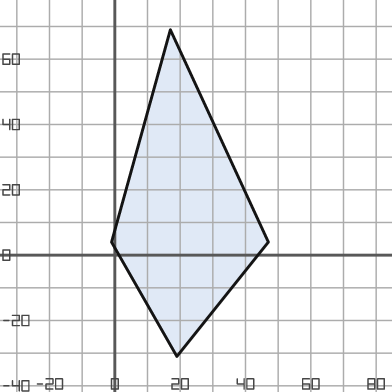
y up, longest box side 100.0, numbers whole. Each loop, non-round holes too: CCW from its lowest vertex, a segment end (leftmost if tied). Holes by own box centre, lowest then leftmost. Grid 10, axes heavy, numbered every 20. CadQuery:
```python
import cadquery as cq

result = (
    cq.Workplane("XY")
    .moveTo(19.0, -31.0)
    .lineTo(47.0, 4.0)
    .lineTo(17.0, 69.0)
    .lineTo(-1.0, 4.0)
    .close()
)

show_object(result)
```